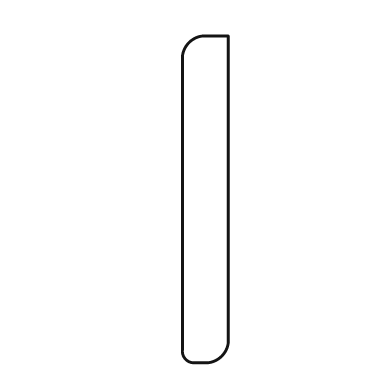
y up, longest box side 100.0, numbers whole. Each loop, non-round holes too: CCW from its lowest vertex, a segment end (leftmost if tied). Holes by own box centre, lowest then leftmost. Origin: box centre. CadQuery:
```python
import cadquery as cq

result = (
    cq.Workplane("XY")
    .moveTo(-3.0, -50.0)
    .lineTo(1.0, -50.0)
    .threePointArc((5.0, -48.0), (7.0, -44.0))
    .lineTo(7.0, 50.0)
    .lineTo(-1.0, 50.0)
    .threePointArc((-5.0, 48.0), (-7.0, 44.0))
    .lineTo(-7.0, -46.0)
    .threePointArc((-6.0, -49.0), (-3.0, -50.0))
    .close()
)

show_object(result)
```